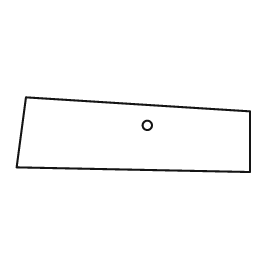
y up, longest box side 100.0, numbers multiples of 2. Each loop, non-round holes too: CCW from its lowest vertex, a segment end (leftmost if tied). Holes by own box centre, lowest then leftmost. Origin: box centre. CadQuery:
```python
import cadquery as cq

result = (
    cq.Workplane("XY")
    .moveTo(50.0, -16.0)
    .lineTo(50.0, 10.0)
    .lineTo(-46.0, 16.0)
    .lineTo(-50.0, -14.0)
    .close()
    .moveTo(6.0, 4.0)
    .circle(2.0)
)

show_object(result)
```